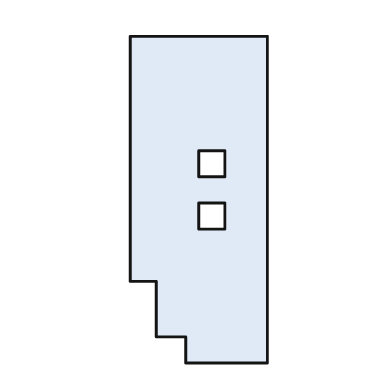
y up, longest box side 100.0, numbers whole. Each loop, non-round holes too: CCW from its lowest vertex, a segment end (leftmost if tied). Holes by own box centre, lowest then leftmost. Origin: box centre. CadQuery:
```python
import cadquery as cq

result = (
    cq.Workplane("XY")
    .moveTo(-4.0, -50.0)
    .lineTo(21.0, -50.0)
    .lineTo(21.0, 50.0)
    .lineTo(-21.0, 50.0)
    .lineTo(-21.0, -25.0)
    .lineTo(-13.0, -25.0)
    .lineTo(-13.0, -42.0)
    .lineTo(-4.0, -42.0)
    .close()
    .moveTo(0.0, -9.0)
    .lineTo(8.0, -9.0)
    .lineTo(8.0, -1.0)
    .lineTo(0.0, -1.0)
    .close()
    .moveTo(0.0, 7.0)
    .lineTo(8.0, 7.0)
    .lineTo(8.0, 15.0)
    .lineTo(0.0, 15.0)
    .close()
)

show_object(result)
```